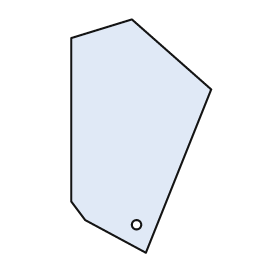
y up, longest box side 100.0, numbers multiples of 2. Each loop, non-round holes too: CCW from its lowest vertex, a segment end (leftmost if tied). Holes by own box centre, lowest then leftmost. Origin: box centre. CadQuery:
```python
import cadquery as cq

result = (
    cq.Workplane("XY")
    .moveTo(2.0, -50.0)
    .lineTo(30.0, 20.0)
    .lineTo(-4.0, 50.0)
    .lineTo(-30.0, 42.0)
    .lineTo(-30.0, -28.0)
    .lineTo(-24.0, -36.0)
    .close()
    .moveTo(-2.0, -38.0)
    .circle(2.0)
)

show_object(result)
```